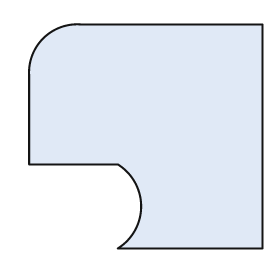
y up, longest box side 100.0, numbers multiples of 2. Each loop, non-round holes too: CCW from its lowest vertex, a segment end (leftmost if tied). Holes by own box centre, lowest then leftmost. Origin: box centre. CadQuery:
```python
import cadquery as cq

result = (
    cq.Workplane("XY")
    .moveTo(-12.0, -48.0)
    .lineTo(50.0, -48.0)
    .lineTo(50.0, 48.0)
    .lineTo(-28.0, 48.0)
    .threePointArc((-44.0, 42.0), (-50.0, 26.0))
    .lineTo(-50.0, -12.0)
    .lineTo(-12.0, -12.0)
    .threePointArc((-2.0, -30.0), (-12.0, -48.0))
    .close()
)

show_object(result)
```